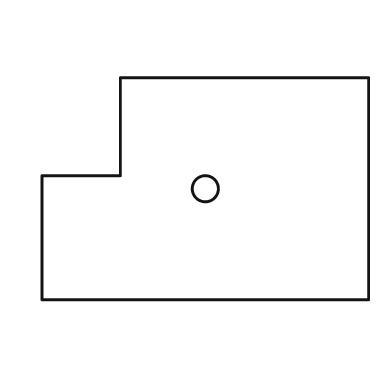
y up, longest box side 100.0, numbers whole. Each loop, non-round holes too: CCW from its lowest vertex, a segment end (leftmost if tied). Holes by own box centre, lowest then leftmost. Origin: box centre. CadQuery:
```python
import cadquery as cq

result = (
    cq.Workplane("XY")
    .moveTo(-50.0, -34.0)
    .lineTo(50.0, -34.0)
    .lineTo(50.0, 34.0)
    .lineTo(-26.0, 34.0)
    .lineTo(-26.0, 4.0)
    .lineTo(-50.0, 4.0)
    .close()
    .moveTo(0.0, 0.0)
    .circle(4.0)
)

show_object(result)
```